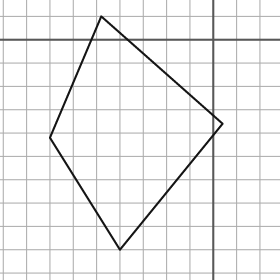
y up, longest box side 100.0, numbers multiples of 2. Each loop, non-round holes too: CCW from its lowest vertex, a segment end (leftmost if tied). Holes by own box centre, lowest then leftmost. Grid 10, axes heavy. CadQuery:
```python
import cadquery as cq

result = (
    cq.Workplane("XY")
    .moveTo(-40.0, -90.0)
    .lineTo(4.0, -36.0)
    .lineTo(-48.0, 10.0)
    .lineTo(-70.0, -42.0)
    .close()
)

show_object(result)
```